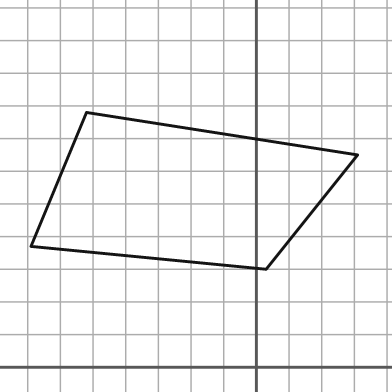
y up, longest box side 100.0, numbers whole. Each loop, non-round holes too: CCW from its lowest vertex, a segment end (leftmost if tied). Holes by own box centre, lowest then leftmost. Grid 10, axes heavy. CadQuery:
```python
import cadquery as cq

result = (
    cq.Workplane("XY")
    .moveTo(3.0, 30.0)
    .lineTo(31.0, 65.0)
    .lineTo(-52.0, 78.0)
    .lineTo(-69.0, 37.0)
    .close()
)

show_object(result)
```